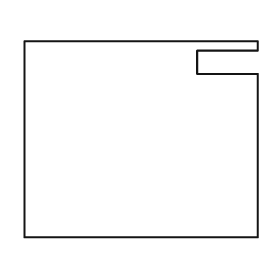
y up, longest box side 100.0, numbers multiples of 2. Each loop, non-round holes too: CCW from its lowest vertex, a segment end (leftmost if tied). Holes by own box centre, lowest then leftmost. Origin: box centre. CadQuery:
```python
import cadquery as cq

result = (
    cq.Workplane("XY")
    .moveTo(-50.0, -42.0)
    .lineTo(50.0, -42.0)
    .lineTo(50.0, 28.0)
    .lineTo(24.0, 28.0)
    .lineTo(24.0, 38.0)
    .lineTo(50.0, 38.0)
    .lineTo(50.0, 42.0)
    .lineTo(-50.0, 42.0)
    .close()
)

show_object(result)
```